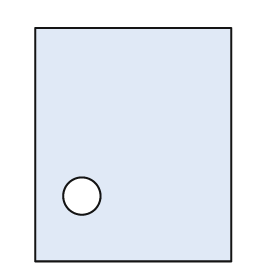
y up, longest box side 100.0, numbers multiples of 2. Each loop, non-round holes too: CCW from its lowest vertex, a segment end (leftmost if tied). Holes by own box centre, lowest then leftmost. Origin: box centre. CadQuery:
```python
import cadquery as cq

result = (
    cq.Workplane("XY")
    .moveTo(-42.0, -50.0)
    .lineTo(42.0, -50.0)
    .lineTo(42.0, 50.0)
    .lineTo(-42.0, 50.0)
    .close()
    .moveTo(-22.0, -22.0)
    .circle(8.0)
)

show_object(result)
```